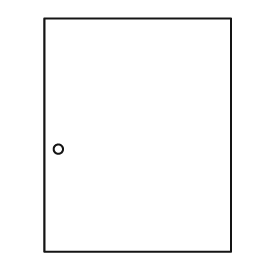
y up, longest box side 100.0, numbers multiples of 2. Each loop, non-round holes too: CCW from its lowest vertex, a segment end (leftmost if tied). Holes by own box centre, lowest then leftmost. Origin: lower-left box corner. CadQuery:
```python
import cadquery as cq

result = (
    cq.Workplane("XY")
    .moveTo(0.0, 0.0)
    .lineTo(80.0, 0.0)
    .lineTo(80.0, 100.0)
    .lineTo(0.0, 100.0)
    .close()
    .moveTo(6.0, 44.0)
    .circle(2.0)
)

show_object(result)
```